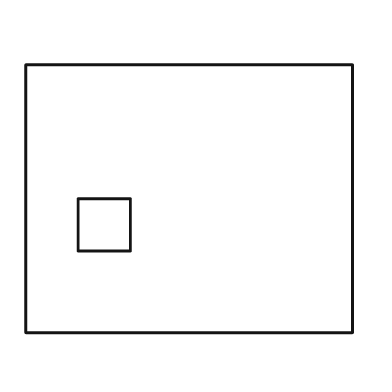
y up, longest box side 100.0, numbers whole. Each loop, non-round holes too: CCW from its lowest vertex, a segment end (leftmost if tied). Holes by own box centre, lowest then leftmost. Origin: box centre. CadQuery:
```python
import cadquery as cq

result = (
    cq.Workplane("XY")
    .moveTo(-50.0, -41.0)
    .lineTo(50.0, -41.0)
    .lineTo(50.0, 41.0)
    .lineTo(-50.0, 41.0)
    .close()
    .moveTo(-34.0, -16.0)
    .lineTo(-18.0, -16.0)
    .lineTo(-18.0, 0.0)
    .lineTo(-34.0, 0.0)
    .close()
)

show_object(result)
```